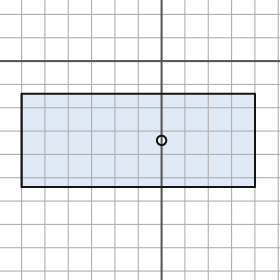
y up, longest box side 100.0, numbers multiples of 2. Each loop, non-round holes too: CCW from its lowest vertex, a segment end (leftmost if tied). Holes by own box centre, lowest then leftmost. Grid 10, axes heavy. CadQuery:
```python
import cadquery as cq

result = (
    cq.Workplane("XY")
    .moveTo(-60.0, -54.0)
    .lineTo(40.0, -54.0)
    .lineTo(40.0, -14.0)
    .lineTo(-60.0, -14.0)
    .close()
    .moveTo(0.0, -34.0)
    .circle(2.0)
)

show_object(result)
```